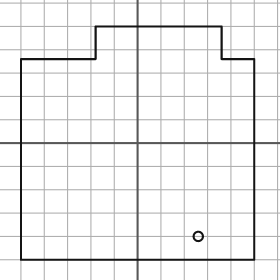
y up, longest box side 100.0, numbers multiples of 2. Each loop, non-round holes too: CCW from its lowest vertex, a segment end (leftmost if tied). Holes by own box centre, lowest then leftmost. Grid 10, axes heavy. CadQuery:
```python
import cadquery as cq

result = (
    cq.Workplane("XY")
    .moveTo(-50.0, -50.0)
    .lineTo(50.0, -50.0)
    .lineTo(50.0, 36.0)
    .lineTo(36.0, 36.0)
    .lineTo(36.0, 50.0)
    .lineTo(-18.0, 50.0)
    .lineTo(-18.0, 36.0)
    .lineTo(-50.0, 36.0)
    .close()
    .moveTo(26.0, -40.0)
    .circle(2.0)
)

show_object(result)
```